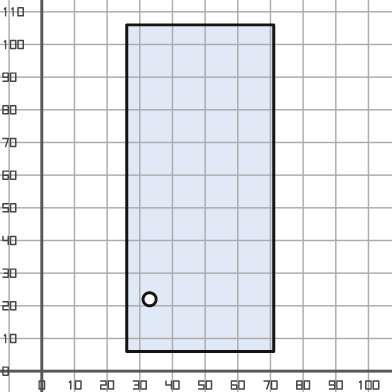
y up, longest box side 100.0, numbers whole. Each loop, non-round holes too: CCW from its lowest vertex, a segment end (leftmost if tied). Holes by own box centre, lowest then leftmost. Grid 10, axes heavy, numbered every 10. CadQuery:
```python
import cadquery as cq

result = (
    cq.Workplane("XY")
    .moveTo(26.0, 6.0)
    .lineTo(71.0, 6.0)
    .lineTo(71.0, 106.0)
    .lineTo(26.0, 106.0)
    .close()
    .moveTo(33.0, 22.0)
    .circle(2.0)
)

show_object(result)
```